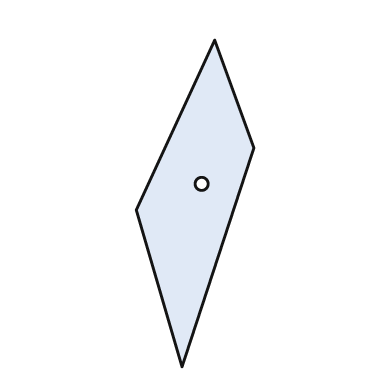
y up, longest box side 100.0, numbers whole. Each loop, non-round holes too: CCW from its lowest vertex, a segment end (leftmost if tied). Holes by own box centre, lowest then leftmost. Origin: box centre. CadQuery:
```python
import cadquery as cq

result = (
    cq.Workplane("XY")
    .moveTo(-4.0, -50.0)
    .lineTo(18.0, 17.0)
    .lineTo(6.0, 50.0)
    .lineTo(-18.0, -2.0)
    .close()
    .moveTo(2.0, 6.0)
    .circle(2.0)
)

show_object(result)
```